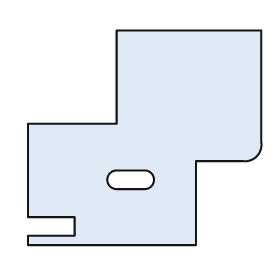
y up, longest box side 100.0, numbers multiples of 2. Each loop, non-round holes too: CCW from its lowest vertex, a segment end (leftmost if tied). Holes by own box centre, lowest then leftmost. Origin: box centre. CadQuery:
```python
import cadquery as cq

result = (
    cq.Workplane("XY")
    .moveTo(-50.0, -46.0)
    .lineTo(22.0, -46.0)
    .lineTo(22.0, -10.0)
    .lineTo(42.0, -10.0)
    .threePointArc((48.0, -8.0), (50.0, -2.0))
    .lineTo(50.0, 46.0)
    .lineTo(-12.0, 46.0)
    .lineTo(-12.0, 6.0)
    .lineTo(-50.0, 6.0)
    .lineTo(-50.0, -34.0)
    .lineTo(-30.0, -34.0)
    .lineTo(-30.0, -42.0)
    .lineTo(-50.0, -42.0)
    .close()
    .moveTo(-12.0, -22.0)
    .lineTo(0.0, -22.0)
    .threePointArc((4.0, -18.0), (0.0, -14.0))
    .lineTo(-12.0, -14.0)
    .threePointArc((-16.0, -18.0), (-12.0, -22.0))
    .close()
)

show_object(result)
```